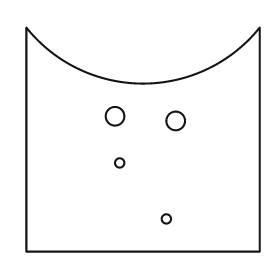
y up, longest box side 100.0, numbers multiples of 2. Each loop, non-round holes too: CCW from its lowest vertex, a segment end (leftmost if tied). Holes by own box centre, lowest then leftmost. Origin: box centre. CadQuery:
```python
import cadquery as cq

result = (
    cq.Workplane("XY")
    .moveTo(-50.0, -48.0)
    .lineTo(50.0, -48.0)
    .lineTo(50.0, 48.0)
    .threePointArc((0.0, 24.0), (-50.0, 48.0))
    .close()
    .moveTo(10.0, -34.0)
    .circle(2.0)
    .moveTo(-10.0, -10.0)
    .circle(2.0)
    .moveTo(14.0, 8.0)
    .circle(4.0)
    .moveTo(-12.0, 10.0)
    .circle(4.0)
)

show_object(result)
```